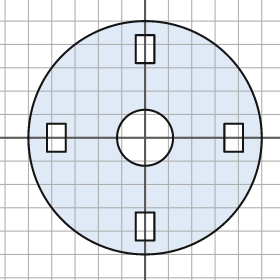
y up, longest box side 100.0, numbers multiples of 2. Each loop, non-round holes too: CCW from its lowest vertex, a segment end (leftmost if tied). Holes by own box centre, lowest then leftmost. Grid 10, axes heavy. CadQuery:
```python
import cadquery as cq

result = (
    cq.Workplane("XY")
    .moveTo(0.0, 0.0)
    .circle(50.0)
    .moveTo(-4.0, -44.0)
    .lineTo(4.0, -44.0)
    .lineTo(4.0, -32.0)
    .lineTo(-4.0, -32.0)
    .close()
    .moveTo(-42.0, -6.0)
    .lineTo(-34.0, -6.0)
    .lineTo(-34.0, 6.0)
    .lineTo(-42.0, 6.0)
    .close()
    .moveTo(0.0, 0.0)
    .circle(12.0)
    .moveTo(34.0, -6.0)
    .lineTo(42.0, -6.0)
    .lineTo(42.0, 6.0)
    .lineTo(34.0, 6.0)
    .close()
    .moveTo(-4.0, 32.0)
    .lineTo(4.0, 32.0)
    .lineTo(4.0, 44.0)
    .lineTo(-4.0, 44.0)
    .close()
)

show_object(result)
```